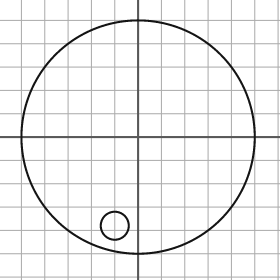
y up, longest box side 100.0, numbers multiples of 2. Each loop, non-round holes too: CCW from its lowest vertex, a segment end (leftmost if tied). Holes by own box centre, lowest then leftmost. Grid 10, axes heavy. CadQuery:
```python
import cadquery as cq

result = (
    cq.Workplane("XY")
    .moveTo(0.0, 0.0)
    .circle(50.0)
    .moveTo(-10.0, -38.0)
    .circle(6.0)
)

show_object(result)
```